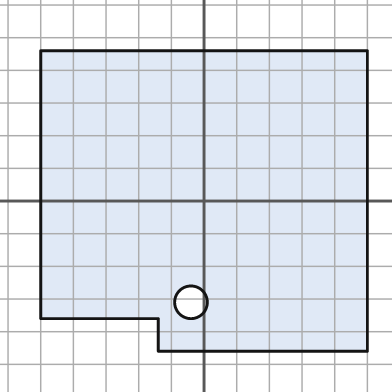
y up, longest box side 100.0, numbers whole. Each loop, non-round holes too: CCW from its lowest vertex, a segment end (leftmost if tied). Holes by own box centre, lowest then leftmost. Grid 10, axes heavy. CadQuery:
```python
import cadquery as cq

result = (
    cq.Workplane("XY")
    .moveTo(-14.0, -46.0)
    .lineTo(50.0, -46.0)
    .lineTo(50.0, 46.0)
    .lineTo(-50.0, 46.0)
    .lineTo(-50.0, -36.0)
    .lineTo(-14.0, -36.0)
    .close()
    .moveTo(-4.0, -31.0)
    .circle(5.0)
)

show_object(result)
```